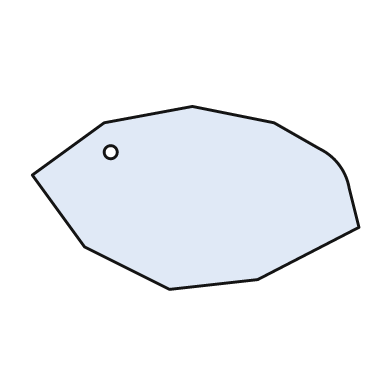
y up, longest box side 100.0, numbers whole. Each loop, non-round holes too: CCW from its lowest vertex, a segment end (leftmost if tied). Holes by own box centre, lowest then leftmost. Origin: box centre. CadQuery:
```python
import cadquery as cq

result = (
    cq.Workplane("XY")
    .moveTo(-8.0, -28.0)
    .lineTo(19.0, -25.0)
    .lineTo(50.0, -9.0)
    .lineTo(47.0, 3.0)
    .threePointArc((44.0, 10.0), (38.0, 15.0))
    .lineTo(24.0, 23.0)
    .lineTo(-1.0, 28.0)
    .lineTo(-28.0, 23.0)
    .lineTo(-50.0, 7.0)
    .lineTo(-34.0, -15.0)
    .close()
    .moveTo(-26.0, 14.0)
    .circle(2.0)
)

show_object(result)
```